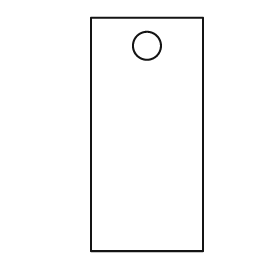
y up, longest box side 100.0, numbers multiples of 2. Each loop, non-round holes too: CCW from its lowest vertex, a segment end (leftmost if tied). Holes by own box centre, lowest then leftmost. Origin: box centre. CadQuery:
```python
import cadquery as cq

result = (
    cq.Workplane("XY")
    .moveTo(-24.0, -50.0)
    .lineTo(24.0, -50.0)
    .lineTo(24.0, 50.0)
    .lineTo(-24.0, 50.0)
    .close()
    .moveTo(0.0, 38.0)
    .circle(6.0)
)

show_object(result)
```